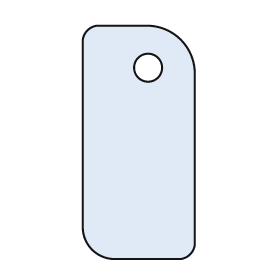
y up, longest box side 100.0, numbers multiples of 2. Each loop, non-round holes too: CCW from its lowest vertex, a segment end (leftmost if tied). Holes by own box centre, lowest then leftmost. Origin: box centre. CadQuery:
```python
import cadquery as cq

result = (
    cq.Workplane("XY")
    .moveTo(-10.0, -50.0)
    .lineTo(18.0, -50.0)
    .threePointArc((22.0, -48.0), (24.0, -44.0))
    .lineTo(24.0, 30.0)
    .threePointArc((18.0, 44.0), (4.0, 50.0))
    .lineTo(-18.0, 50.0)
    .threePointArc((-22.0, 48.0), (-24.0, 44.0))
    .lineTo(-24.0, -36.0)
    .threePointArc((-20.0, -46.0), (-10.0, -50.0))
    .close()
    .moveTo(4.0, 32.0)
    .circle(6.0)
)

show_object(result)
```